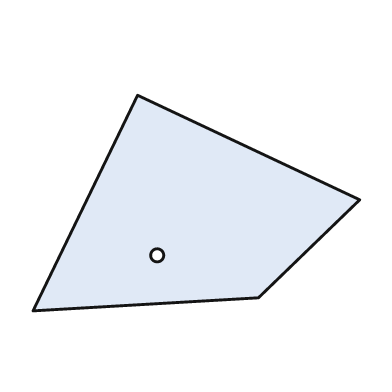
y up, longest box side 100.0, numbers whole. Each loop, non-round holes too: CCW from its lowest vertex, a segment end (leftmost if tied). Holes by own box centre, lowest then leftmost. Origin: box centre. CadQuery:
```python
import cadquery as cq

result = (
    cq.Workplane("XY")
    .moveTo(-50.0, -33.0)
    .lineTo(19.0, -29.0)
    .lineTo(50.0, 1.0)
    .lineTo(-18.0, 33.0)
    .close()
    .moveTo(-12.0, -16.0)
    .circle(2.0)
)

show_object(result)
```